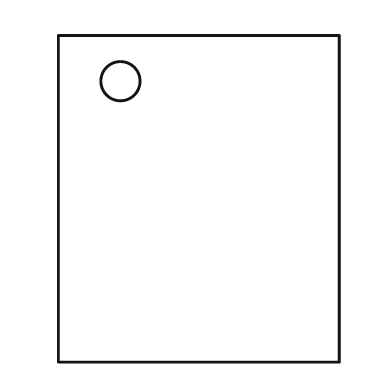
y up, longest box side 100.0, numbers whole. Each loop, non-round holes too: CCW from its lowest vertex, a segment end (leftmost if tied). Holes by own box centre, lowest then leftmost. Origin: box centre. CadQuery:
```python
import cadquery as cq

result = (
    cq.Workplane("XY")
    .moveTo(-43.0, -50.0)
    .lineTo(43.0, -50.0)
    .lineTo(43.0, 50.0)
    .lineTo(-43.0, 50.0)
    .close()
    .moveTo(-24.0, 36.0)
    .circle(6.0)
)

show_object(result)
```